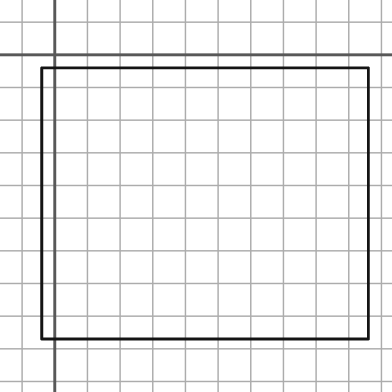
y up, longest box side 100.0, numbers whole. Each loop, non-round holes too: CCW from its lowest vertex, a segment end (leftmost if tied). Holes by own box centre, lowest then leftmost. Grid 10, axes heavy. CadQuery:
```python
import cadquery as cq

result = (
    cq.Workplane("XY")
    .moveTo(-4.0, -87.0)
    .lineTo(96.0, -87.0)
    .lineTo(96.0, -4.0)
    .lineTo(-4.0, -4.0)
    .close()
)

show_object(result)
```